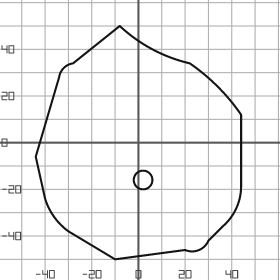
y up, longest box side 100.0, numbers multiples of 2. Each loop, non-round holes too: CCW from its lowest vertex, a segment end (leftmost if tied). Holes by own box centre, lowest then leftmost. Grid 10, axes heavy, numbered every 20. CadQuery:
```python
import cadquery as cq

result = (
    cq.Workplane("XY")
    .moveTo(-10.0, -50.0)
    .lineTo(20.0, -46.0)
    .threePointArc((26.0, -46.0), (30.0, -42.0))
    .lineTo(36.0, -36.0)
    .threePointArc((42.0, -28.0), (44.0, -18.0))
    .lineTo(44.0, 12.0)
    .threePointArc((34.0, 24.0), (22.0, 34.0))
    .threePointArc((6.0, 40.0), (-8.0, 50.0))
    .lineTo(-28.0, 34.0)
    .threePointArc((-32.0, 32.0), (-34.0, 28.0))
    .lineTo(-44.0, -6.0)
    .lineTo(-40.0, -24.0)
    .threePointArc((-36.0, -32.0), (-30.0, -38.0))
    .close()
    .moveTo(2.0, -16.0)
    .circle(4.0)
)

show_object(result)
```